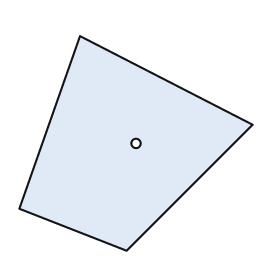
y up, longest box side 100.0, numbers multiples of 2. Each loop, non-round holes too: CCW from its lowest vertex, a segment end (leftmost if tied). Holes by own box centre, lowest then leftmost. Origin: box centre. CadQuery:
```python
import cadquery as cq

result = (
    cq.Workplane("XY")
    .moveTo(-4.0, -46.0)
    .lineTo(50.0, 8.0)
    .lineTo(-24.0, 46.0)
    .lineTo(-50.0, -28.0)
    .close()
    .moveTo(0.0, 0.0)
    .circle(2.0)
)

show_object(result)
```